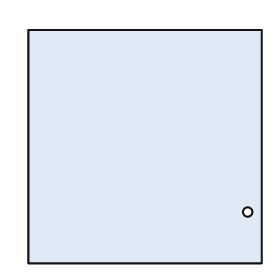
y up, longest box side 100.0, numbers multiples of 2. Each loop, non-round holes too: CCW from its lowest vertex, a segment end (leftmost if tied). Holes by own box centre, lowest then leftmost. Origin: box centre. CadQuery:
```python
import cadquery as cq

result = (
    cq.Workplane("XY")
    .moveTo(-50.0, -50.0)
    .lineTo(50.0, -50.0)
    .lineTo(50.0, 50.0)
    .lineTo(-50.0, 50.0)
    .close()
    .moveTo(44.0, -28.0)
    .circle(2.0)
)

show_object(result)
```